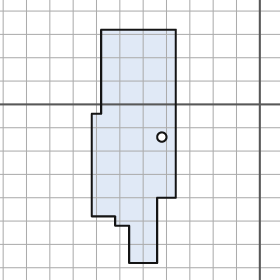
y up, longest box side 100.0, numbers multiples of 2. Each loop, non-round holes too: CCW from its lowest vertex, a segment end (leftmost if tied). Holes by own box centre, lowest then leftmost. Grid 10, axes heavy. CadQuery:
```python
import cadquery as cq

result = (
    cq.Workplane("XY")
    .moveTo(-56.0, -68.0)
    .lineTo(-44.0, -68.0)
    .lineTo(-44.0, -40.0)
    .lineTo(-36.0, -40.0)
    .lineTo(-36.0, 32.0)
    .lineTo(-68.0, 32.0)
    .lineTo(-68.0, -4.0)
    .lineTo(-72.0, -4.0)
    .lineTo(-72.0, -48.0)
    .lineTo(-62.0, -48.0)
    .lineTo(-62.0, -52.0)
    .lineTo(-56.0, -52.0)
    .close()
    .moveTo(-42.0, -14.0)
    .circle(2.0)
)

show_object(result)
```